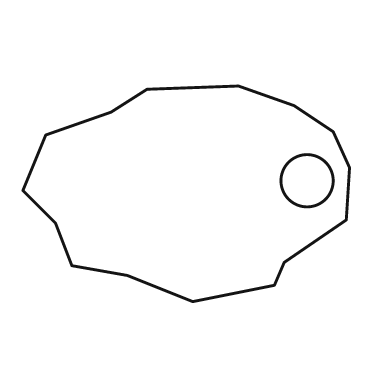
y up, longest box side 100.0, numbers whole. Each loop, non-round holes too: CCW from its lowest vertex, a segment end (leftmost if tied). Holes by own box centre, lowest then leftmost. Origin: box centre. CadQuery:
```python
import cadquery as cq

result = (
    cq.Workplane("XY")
    .moveTo(2.0, -33.0)
    .lineTo(27.0, -28.0)
    .lineTo(30.0, -21.0)
    .lineTo(49.0, -8.0)
    .lineTo(50.0, 8.0)
    .lineTo(45.0, 19.0)
    .lineTo(33.0, 27.0)
    .lineTo(16.0, 33.0)
    .lineTo(-12.0, 32.0)
    .lineTo(-23.0, 25.0)
    .lineTo(-43.0, 18.0)
    .lineTo(-50.0, 1.0)
    .lineTo(-40.0, -9.0)
    .lineTo(-35.0, -22.0)
    .lineTo(-18.0, -25.0)
    .close()
    .moveTo(37.0, 4.0)
    .circle(8.0)
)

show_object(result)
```